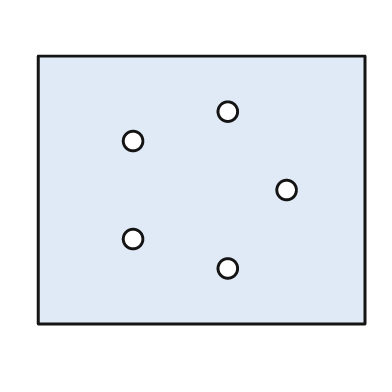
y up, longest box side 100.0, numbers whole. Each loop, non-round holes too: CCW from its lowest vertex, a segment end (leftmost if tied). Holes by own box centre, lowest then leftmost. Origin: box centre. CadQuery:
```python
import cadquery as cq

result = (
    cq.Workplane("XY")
    .moveTo(-50.0, -41.0)
    .lineTo(50.0, -41.0)
    .lineTo(50.0, 41.0)
    .lineTo(-50.0, 41.0)
    .close()
    .moveTo(8.0, -24.0)
    .circle(3.0)
    .moveTo(-21.0, -15.0)
    .circle(3.0)
    .moveTo(26.0, 0.0)
    .circle(3.0)
    .moveTo(-21.0, 15.0)
    .circle(3.0)
    .moveTo(8.0, 24.0)
    .circle(3.0)
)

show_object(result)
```